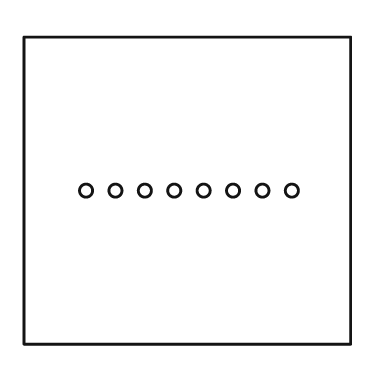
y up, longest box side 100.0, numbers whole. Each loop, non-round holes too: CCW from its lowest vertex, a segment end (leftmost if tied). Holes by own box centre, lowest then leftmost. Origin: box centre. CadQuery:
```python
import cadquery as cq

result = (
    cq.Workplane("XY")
    .moveTo(-50.0, -47.0)
    .lineTo(50.0, -47.0)
    .lineTo(50.0, 47.0)
    .lineTo(-50.0, 47.0)
    .close()
    .moveTo(-31.0, 0.0)
    .circle(2.0)
    .moveTo(-22.0, 0.0)
    .circle(2.0)
    .moveTo(-13.0, 0.0)
    .circle(2.0)
    .moveTo(-4.0, 0.0)
    .circle(2.0)
    .moveTo(5.0, 0.0)
    .circle(2.0)
    .moveTo(14.0, 0.0)
    .circle(2.0)
    .moveTo(23.0, 0.0)
    .circle(2.0)
    .moveTo(32.0, 0.0)
    .circle(2.0)
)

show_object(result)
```